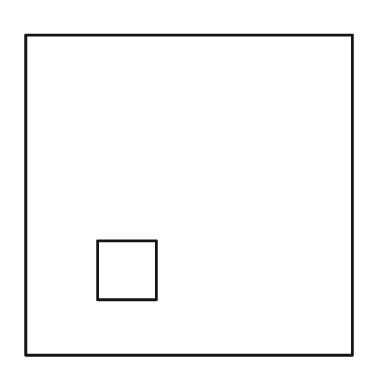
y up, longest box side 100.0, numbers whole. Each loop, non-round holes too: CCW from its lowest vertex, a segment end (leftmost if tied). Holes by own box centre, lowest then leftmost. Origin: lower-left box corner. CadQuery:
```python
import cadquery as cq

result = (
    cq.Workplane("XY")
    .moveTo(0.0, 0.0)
    .lineTo(100.0, 0.0)
    .lineTo(100.0, 98.0)
    .lineTo(0.0, 98.0)
    .close()
    .moveTo(22.0, 17.0)
    .lineTo(40.0, 17.0)
    .lineTo(40.0, 35.0)
    .lineTo(22.0, 35.0)
    .close()
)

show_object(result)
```